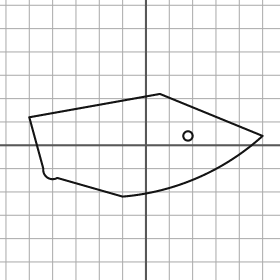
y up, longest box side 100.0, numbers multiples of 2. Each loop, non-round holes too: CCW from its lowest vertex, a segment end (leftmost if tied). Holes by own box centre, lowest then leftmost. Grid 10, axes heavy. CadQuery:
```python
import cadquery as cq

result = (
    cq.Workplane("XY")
    .moveTo(-10.0, -22.0)
    .threePointArc((22.0, -14.0), (50.0, 4.0))
    .lineTo(6.0, 22.0)
    .lineTo(-50.0, 12.0)
    .lineTo(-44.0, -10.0)
    .threePointArc((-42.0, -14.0), (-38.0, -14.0))
    .close()
    .moveTo(18.0, 4.0)
    .circle(2.0)
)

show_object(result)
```